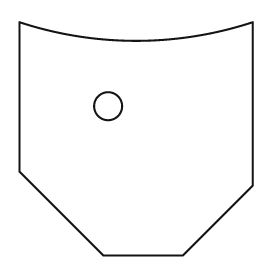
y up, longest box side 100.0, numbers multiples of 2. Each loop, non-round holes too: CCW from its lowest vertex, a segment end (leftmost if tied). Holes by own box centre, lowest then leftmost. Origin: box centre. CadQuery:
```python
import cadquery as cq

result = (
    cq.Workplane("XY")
    .moveTo(-14.0, -50.0)
    .lineTo(20.0, -50.0)
    .lineTo(50.0, -20.0)
    .lineTo(50.0, 50.0)
    .threePointArc((0.0, 42.0), (-50.0, 50.0))
    .lineTo(-50.0, -14.0)
    .close()
    .moveTo(-12.0, 14.0)
    .circle(6.0)
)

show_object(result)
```